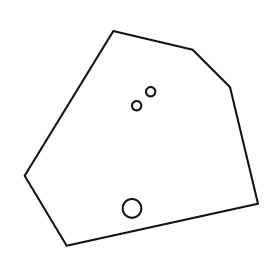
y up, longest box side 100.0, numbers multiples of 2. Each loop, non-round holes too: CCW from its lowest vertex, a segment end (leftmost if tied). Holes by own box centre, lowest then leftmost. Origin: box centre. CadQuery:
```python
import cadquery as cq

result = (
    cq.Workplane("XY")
    .moveTo(-32.0, -46.0)
    .lineTo(50.0, -28.0)
    .lineTo(38.0, 22.0)
    .lineTo(22.0, 38.0)
    .lineTo(-12.0, 46.0)
    .lineTo(-50.0, -16.0)
    .close()
    .moveTo(-4.0, -30.0)
    .circle(4.0)
    .moveTo(-2.0, 14.0)
    .circle(2.0)
    .moveTo(4.0, 20.0)
    .circle(2.0)
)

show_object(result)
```